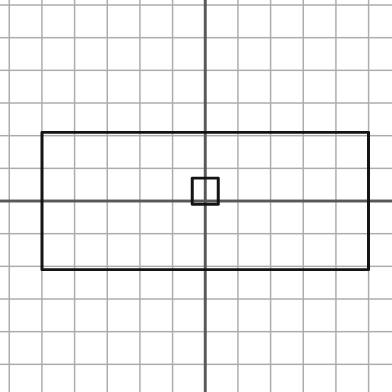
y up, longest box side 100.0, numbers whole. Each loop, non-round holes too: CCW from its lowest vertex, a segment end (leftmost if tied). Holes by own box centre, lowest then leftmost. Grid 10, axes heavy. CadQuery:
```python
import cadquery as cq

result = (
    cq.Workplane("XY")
    .moveTo(-50.0, -21.0)
    .lineTo(50.0, -21.0)
    .lineTo(50.0, 21.0)
    .lineTo(-50.0, 21.0)
    .close()
    .moveTo(-4.0, -1.0)
    .lineTo(4.0, -1.0)
    .lineTo(4.0, 7.0)
    .lineTo(-4.0, 7.0)
    .close()
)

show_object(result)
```